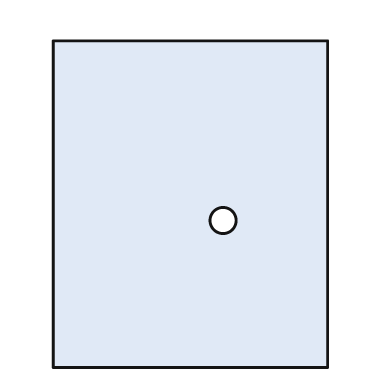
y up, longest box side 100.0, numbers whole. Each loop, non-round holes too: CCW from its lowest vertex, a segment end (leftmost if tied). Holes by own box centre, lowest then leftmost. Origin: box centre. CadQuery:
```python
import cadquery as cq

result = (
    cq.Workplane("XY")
    .moveTo(-42.0, -50.0)
    .lineTo(42.0, -50.0)
    .lineTo(42.0, 50.0)
    .lineTo(-42.0, 50.0)
    .close()
    .moveTo(10.0, -5.0)
    .circle(4.0)
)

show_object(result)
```